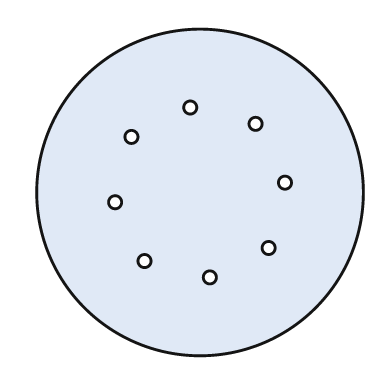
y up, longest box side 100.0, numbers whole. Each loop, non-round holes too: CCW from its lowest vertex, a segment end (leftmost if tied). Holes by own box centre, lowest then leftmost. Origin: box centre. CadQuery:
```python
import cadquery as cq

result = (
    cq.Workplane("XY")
    .moveTo(0.0, 0.0)
    .circle(50.0)
    .moveTo(3.0, -26.0)
    .circle(2.0)
    .moveTo(-17.0, -21.0)
    .circle(2.0)
    .moveTo(21.0, -17.0)
    .circle(2.0)
    .moveTo(-26.0, -3.0)
    .circle(2.0)
    .moveTo(26.0, 3.0)
    .circle(2.0)
    .moveTo(-21.0, 17.0)
    .circle(2.0)
    .moveTo(17.0, 21.0)
    .circle(2.0)
    .moveTo(-3.0, 26.0)
    .circle(2.0)
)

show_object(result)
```